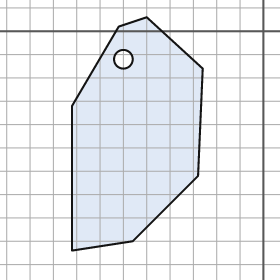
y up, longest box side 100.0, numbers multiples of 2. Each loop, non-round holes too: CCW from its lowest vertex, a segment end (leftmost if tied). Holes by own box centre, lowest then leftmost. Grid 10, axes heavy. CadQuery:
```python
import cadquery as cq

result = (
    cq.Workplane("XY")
    .moveTo(-82.0, -94.0)
    .lineTo(-56.0, -90.0)
    .lineTo(-28.0, -62.0)
    .lineTo(-26.0, -16.0)
    .lineTo(-50.0, 6.0)
    .lineTo(-62.0, 2.0)
    .lineTo(-82.0, -32.0)
    .close()
    .moveTo(-60.0, -12.0)
    .circle(4.0)
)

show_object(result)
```